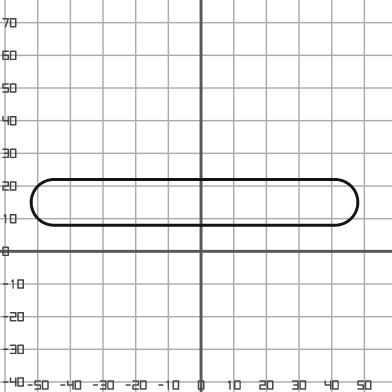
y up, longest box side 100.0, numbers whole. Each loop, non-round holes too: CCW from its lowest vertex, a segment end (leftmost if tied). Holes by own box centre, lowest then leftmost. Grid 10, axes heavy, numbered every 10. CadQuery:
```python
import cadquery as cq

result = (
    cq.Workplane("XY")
    .moveTo(-45.0, 8.0)
    .lineTo(41.0, 8.0)
    .threePointArc((48.0, 15.0), (41.0, 22.0))
    .lineTo(-45.0, 22.0)
    .threePointArc((-52.0, 15.0), (-45.0, 8.0))
    .close()
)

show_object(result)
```